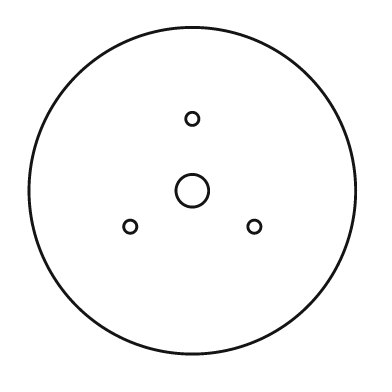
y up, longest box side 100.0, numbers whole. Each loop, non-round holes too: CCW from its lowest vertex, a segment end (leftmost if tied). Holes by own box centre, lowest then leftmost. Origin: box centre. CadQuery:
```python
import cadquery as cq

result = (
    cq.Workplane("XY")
    .moveTo(0.0, 0.0)
    .circle(50.0)
    .moveTo(-19.0, -11.0)
    .circle(2.0)
    .moveTo(19.0, -11.0)
    .circle(2.0)
    .moveTo(0.0, 0.0)
    .circle(5.0)
    .moveTo(0.0, 22.0)
    .circle(2.0)
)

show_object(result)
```